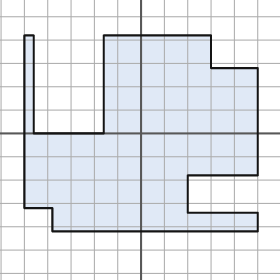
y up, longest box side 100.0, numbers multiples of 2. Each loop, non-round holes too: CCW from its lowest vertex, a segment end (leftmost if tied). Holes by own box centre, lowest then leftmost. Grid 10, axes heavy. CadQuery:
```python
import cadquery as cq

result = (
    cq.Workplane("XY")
    .moveTo(-38.0, -42.0)
    .lineTo(50.0, -42.0)
    .lineTo(50.0, -34.0)
    .lineTo(20.0, -34.0)
    .lineTo(20.0, -18.0)
    .lineTo(50.0, -18.0)
    .lineTo(50.0, 28.0)
    .lineTo(30.0, 28.0)
    .lineTo(30.0, 42.0)
    .lineTo(-16.0, 42.0)
    .lineTo(-16.0, 0.0)
    .lineTo(-46.0, 0.0)
    .lineTo(-46.0, 42.0)
    .lineTo(-50.0, 42.0)
    .lineTo(-50.0, -32.0)
    .lineTo(-38.0, -32.0)
    .close()
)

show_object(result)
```